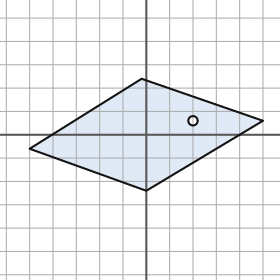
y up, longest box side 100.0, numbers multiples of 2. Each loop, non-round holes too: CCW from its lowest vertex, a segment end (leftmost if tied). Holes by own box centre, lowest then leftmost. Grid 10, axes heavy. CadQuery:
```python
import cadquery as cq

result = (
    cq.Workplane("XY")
    .moveTo(0.0, -24.0)
    .lineTo(50.0, 6.0)
    .lineTo(-2.0, 24.0)
    .lineTo(-50.0, -6.0)
    .close()
    .moveTo(20.0, 6.0)
    .circle(2.0)
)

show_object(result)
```